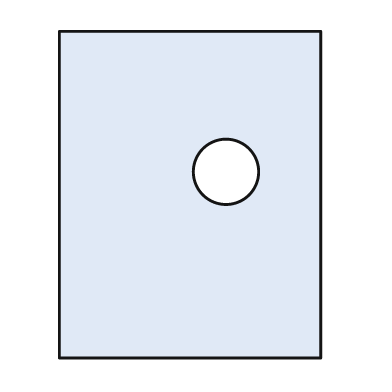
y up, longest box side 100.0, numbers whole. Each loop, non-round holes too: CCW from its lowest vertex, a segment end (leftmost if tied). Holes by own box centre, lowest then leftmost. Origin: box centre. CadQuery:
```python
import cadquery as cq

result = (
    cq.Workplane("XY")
    .moveTo(-40.0, -50.0)
    .lineTo(40.0, -50.0)
    .lineTo(40.0, 50.0)
    .lineTo(-40.0, 50.0)
    .close()
    .moveTo(11.0, 7.0)
    .circle(10.0)
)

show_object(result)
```